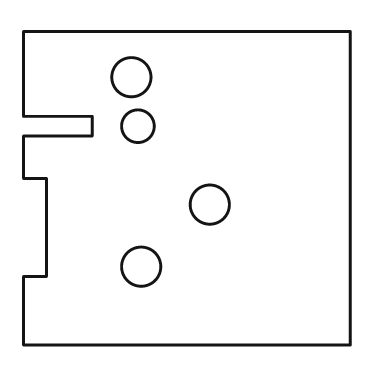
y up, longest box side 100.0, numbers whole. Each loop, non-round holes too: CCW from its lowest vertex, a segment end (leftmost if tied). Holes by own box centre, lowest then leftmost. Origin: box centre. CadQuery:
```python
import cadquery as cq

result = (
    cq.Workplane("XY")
    .moveTo(-50.0, -48.0)
    .lineTo(50.0, -48.0)
    .lineTo(50.0, 48.0)
    .lineTo(-50.0, 48.0)
    .lineTo(-50.0, 22.0)
    .lineTo(-29.0, 22.0)
    .lineTo(-29.0, 16.0)
    .lineTo(-50.0, 16.0)
    .lineTo(-50.0, 3.0)
    .lineTo(-43.0, 3.0)
    .lineTo(-43.0, -27.0)
    .lineTo(-50.0, -27.0)
    .close()
    .moveTo(-14.0, -24.0)
    .circle(6.0)
    .moveTo(7.0, -5.0)
    .circle(6.0)
    .moveTo(-15.0, 19.0)
    .circle(5.0)
    .moveTo(-17.0, 34.0)
    .circle(6.0)
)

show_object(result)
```